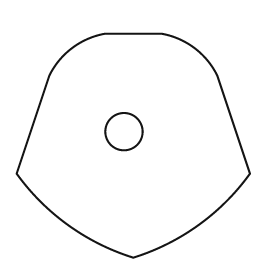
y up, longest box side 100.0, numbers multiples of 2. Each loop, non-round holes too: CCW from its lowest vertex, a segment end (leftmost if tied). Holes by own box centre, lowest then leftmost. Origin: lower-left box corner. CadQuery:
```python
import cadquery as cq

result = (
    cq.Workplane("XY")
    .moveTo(50.0, 0.0)
    .threePointArc((78.0, 14.0), (100.0, 36.0))
    .lineTo(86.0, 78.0)
    .threePointArc((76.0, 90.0), (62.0, 96.0))
    .lineTo(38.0, 96.0)
    .threePointArc((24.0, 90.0), (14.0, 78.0))
    .lineTo(0.0, 36.0)
    .threePointArc((22.0, 14.0), (50.0, 0.0))
    .close()
    .moveTo(46.0, 54.0)
    .circle(8.0)
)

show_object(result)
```